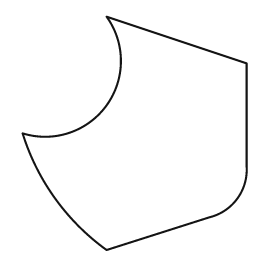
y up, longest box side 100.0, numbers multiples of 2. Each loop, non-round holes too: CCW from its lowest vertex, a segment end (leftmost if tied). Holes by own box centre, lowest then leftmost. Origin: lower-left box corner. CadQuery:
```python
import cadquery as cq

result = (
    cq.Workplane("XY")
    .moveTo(36.0, 0.0)
    .lineTo(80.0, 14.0)
    .threePointArc((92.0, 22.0), (96.0, 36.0))
    .lineTo(96.0, 80.0)
    .lineTo(36.0, 100.0)
    .threePointArc((36.0, 62.0), (0.0, 50.0))
    .threePointArc((14.0, 22.0), (36.0, 0.0))
    .close()
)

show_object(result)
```